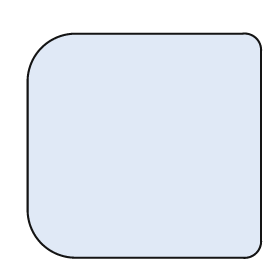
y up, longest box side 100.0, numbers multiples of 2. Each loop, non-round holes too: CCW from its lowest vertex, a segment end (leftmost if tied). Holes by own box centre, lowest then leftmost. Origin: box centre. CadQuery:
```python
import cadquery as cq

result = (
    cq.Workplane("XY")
    .moveTo(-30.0, -48.0)
    .lineTo(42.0, -48.0)
    .threePointArc((48.0, -46.0), (50.0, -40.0))
    .lineTo(50.0, 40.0)
    .threePointArc((48.0, 46.0), (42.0, 48.0))
    .lineTo(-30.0, 48.0)
    .threePointArc((-44.0, 42.0), (-50.0, 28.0))
    .lineTo(-50.0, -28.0)
    .threePointArc((-44.0, -42.0), (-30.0, -48.0))
    .close()
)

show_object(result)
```